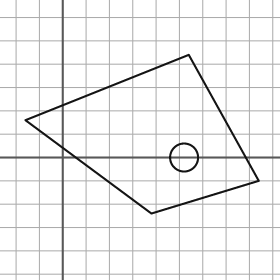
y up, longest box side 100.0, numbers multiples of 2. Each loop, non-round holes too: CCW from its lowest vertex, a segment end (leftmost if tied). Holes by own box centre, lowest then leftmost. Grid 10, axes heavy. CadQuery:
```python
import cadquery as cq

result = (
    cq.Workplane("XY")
    .moveTo(38.0, -24.0)
    .lineTo(84.0, -10.0)
    .lineTo(54.0, 44.0)
    .lineTo(-16.0, 16.0)
    .close()
    .moveTo(52.0, 0.0)
    .circle(6.0)
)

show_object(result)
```